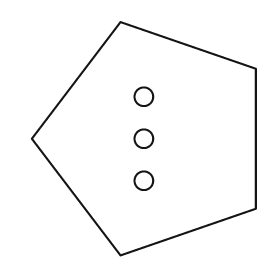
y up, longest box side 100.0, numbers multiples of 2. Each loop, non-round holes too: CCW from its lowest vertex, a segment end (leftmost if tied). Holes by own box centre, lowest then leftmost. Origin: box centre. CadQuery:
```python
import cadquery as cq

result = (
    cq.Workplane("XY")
    .moveTo(-10.0, -50.0)
    .lineTo(48.0, -30.0)
    .lineTo(48.0, 30.0)
    .lineTo(-10.0, 50.0)
    .lineTo(-48.0, 0.0)
    .close()
    .moveTo(0.0, -18.0)
    .circle(4.0)
    .moveTo(0.0, 0.0)
    .circle(4.0)
    .moveTo(0.0, 18.0)
    .circle(4.0)
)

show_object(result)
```